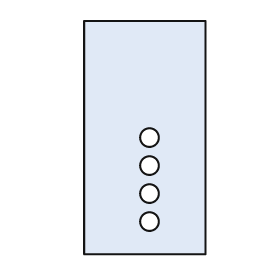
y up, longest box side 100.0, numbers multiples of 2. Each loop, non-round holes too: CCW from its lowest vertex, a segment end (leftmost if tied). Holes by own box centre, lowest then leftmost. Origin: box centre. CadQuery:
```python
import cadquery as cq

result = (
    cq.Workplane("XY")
    .moveTo(-26.0, -50.0)
    .lineTo(26.0, -50.0)
    .lineTo(26.0, 50.0)
    .lineTo(-26.0, 50.0)
    .close()
    .moveTo(2.0, -36.0)
    .circle(4.0)
    .moveTo(2.0, -24.0)
    .circle(4.0)
    .moveTo(2.0, -12.0)
    .circle(4.0)
    .moveTo(2.0, 0.0)
    .circle(4.0)
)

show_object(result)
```